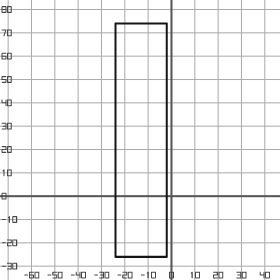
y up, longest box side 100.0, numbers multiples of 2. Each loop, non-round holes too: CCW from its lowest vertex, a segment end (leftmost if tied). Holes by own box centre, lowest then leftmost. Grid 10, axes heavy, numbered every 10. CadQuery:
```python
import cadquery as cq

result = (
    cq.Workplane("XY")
    .moveTo(-24.0, -26.0)
    .lineTo(-2.0, -26.0)
    .lineTo(-2.0, 74.0)
    .lineTo(-24.0, 74.0)
    .close()
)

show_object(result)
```